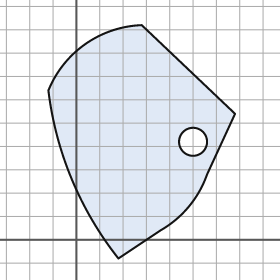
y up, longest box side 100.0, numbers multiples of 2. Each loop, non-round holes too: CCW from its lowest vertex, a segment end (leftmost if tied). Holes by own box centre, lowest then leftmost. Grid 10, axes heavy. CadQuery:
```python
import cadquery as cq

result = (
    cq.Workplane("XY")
    .moveTo(18.0, -8.0)
    .lineTo(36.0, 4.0)
    .threePointArc((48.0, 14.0), (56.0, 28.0))
    .lineTo(68.0, 54.0)
    .lineTo(28.0, 92.0)
    .threePointArc((4.0, 84.0), (-12.0, 64.0))
    .threePointArc((-2.0, 26.0), (18.0, -8.0))
    .close()
    .moveTo(50.0, 42.0)
    .circle(6.0)
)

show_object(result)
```